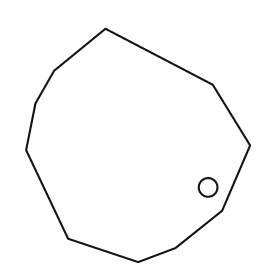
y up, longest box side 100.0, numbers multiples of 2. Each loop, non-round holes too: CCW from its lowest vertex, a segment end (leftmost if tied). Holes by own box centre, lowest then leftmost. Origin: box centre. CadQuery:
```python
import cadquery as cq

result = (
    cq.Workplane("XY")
    .moveTo(0.0, -50.0)
    .lineTo(16.0, -44.0)
    .lineTo(36.0, -28.0)
    .lineTo(48.0, 0.0)
    .lineTo(32.0, 26.0)
    .lineTo(-14.0, 50.0)
    .lineTo(-36.0, 32.0)
    .lineTo(-44.0, 18.0)
    .lineTo(-48.0, -2.0)
    .lineTo(-30.0, -40.0)
    .close()
    .moveTo(30.0, -18.0)
    .circle(4.0)
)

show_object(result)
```